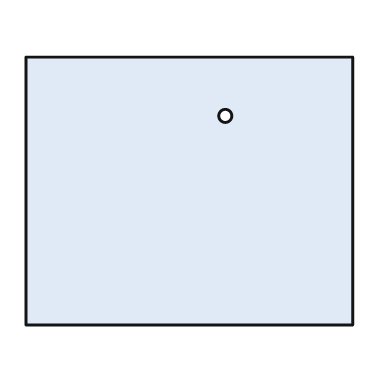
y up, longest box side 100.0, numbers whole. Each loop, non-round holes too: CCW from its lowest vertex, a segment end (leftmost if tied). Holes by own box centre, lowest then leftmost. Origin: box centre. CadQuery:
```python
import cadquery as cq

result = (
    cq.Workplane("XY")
    .moveTo(-50.0, -41.0)
    .lineTo(50.0, -41.0)
    .lineTo(50.0, 41.0)
    .lineTo(-50.0, 41.0)
    .close()
    .moveTo(11.0, 23.0)
    .circle(2.0)
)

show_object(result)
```